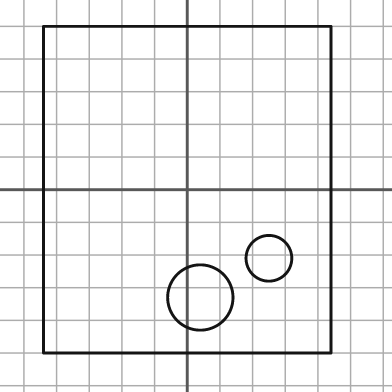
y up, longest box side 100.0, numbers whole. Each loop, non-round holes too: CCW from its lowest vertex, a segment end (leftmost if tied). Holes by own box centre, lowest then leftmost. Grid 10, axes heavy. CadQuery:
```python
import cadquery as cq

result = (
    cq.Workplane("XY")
    .moveTo(-44.0, -50.0)
    .lineTo(44.0, -50.0)
    .lineTo(44.0, 50.0)
    .lineTo(-44.0, 50.0)
    .close()
    .moveTo(4.0, -33.0)
    .circle(10.0)
    .moveTo(25.0, -21.0)
    .circle(7.0)
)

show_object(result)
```